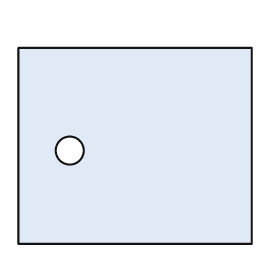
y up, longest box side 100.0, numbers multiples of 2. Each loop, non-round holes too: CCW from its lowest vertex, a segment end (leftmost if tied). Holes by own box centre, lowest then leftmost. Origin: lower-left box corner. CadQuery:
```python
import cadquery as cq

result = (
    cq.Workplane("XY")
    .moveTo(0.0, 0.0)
    .lineTo(100.0, 0.0)
    .lineTo(100.0, 84.0)
    .lineTo(0.0, 84.0)
    .close()
    .moveTo(22.0, 40.0)
    .circle(6.0)
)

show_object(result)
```